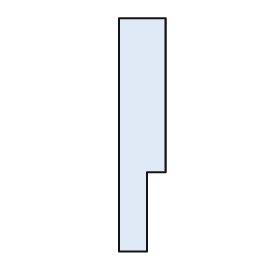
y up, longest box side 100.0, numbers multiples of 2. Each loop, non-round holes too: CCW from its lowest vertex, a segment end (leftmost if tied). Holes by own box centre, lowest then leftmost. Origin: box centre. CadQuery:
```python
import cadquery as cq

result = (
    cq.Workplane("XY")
    .moveTo(-10.0, -50.0)
    .lineTo(2.0, -50.0)
    .lineTo(2.0, -16.0)
    .lineTo(10.0, -16.0)
    .lineTo(10.0, 50.0)
    .lineTo(-10.0, 50.0)
    .close()
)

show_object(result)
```